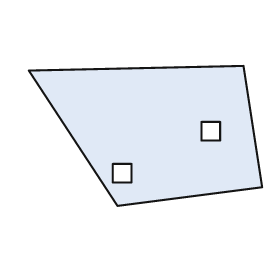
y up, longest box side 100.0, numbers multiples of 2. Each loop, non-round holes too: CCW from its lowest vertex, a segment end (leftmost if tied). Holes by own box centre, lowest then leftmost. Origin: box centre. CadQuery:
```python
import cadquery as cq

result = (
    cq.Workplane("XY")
    .moveTo(-12.0, -30.0)
    .lineTo(50.0, -22.0)
    .lineTo(42.0, 30.0)
    .lineTo(-50.0, 28.0)
    .close()
    .moveTo(-14.0, -20.0)
    .lineTo(-6.0, -20.0)
    .lineTo(-6.0, -12.0)
    .lineTo(-14.0, -12.0)
    .close()
    .moveTo(24.0, -2.0)
    .lineTo(32.0, -2.0)
    .lineTo(32.0, 6.0)
    .lineTo(24.0, 6.0)
    .close()
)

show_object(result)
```